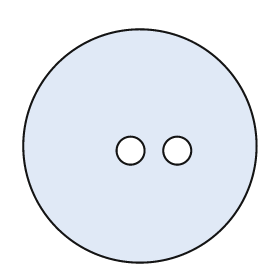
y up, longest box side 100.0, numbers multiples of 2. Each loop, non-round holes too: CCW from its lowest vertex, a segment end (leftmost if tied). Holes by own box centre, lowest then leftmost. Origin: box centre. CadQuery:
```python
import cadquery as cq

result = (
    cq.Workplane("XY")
    .moveTo(0.0, 0.0)
    .circle(50.0)
    .moveTo(-4.0, -2.0)
    .circle(6.0)
    .moveTo(16.0, -2.0)
    .circle(6.0)
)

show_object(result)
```